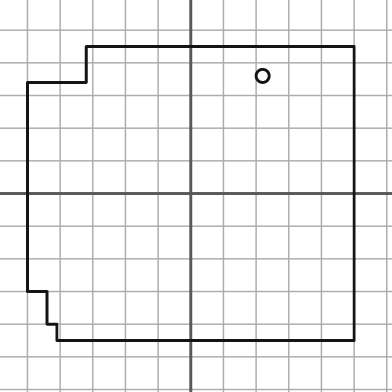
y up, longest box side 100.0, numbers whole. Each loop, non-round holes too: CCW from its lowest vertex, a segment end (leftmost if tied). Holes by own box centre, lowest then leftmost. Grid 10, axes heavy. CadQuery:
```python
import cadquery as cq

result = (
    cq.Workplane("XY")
    .moveTo(-41.0, -45.0)
    .lineTo(50.0, -45.0)
    .lineTo(50.0, 45.0)
    .lineTo(-32.0, 45.0)
    .lineTo(-32.0, 34.0)
    .lineTo(-50.0, 34.0)
    .lineTo(-50.0, -30.0)
    .lineTo(-44.0, -30.0)
    .lineTo(-44.0, -40.0)
    .lineTo(-41.0, -40.0)
    .close()
    .moveTo(22.0, 36.0)
    .circle(2.0)
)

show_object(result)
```